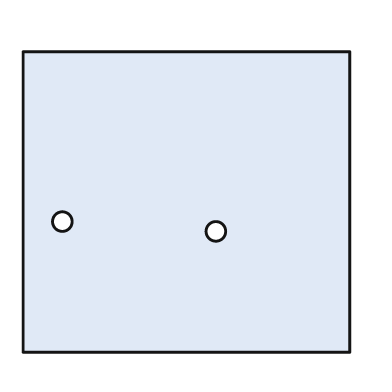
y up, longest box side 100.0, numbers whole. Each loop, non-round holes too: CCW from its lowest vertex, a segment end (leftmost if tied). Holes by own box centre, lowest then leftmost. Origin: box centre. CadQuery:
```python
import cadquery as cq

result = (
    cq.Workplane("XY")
    .moveTo(-50.0, -46.0)
    .lineTo(50.0, -46.0)
    .lineTo(50.0, 46.0)
    .lineTo(-50.0, 46.0)
    .close()
    .moveTo(9.0, -9.0)
    .circle(3.0)
    .moveTo(-38.0, -6.0)
    .circle(3.0)
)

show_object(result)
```